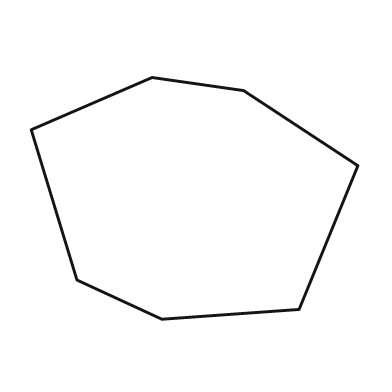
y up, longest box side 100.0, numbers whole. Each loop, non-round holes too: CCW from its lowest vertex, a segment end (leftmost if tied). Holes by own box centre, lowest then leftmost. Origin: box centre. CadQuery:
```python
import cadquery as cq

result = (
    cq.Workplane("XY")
    .moveTo(-10.0, -37.0)
    .lineTo(32.0, -34.0)
    .lineTo(50.0, 10.0)
    .lineTo(15.0, 33.0)
    .lineTo(-13.0, 37.0)
    .lineTo(-50.0, 21.0)
    .lineTo(-36.0, -25.0)
    .close()
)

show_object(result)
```